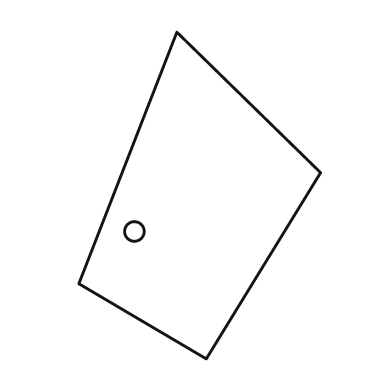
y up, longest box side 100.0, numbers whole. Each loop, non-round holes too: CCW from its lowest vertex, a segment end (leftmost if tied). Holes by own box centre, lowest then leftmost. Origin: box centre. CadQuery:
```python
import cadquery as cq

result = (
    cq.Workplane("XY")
    .moveTo(2.0, -50.0)
    .lineTo(37.0, 7.0)
    .lineTo(-7.0, 50.0)
    .lineTo(-37.0, -27.0)
    .close()
    .moveTo(-20.0, -11.0)
    .circle(3.0)
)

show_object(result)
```